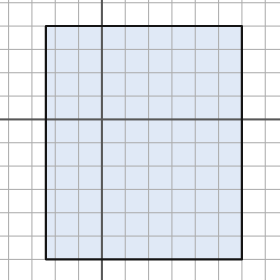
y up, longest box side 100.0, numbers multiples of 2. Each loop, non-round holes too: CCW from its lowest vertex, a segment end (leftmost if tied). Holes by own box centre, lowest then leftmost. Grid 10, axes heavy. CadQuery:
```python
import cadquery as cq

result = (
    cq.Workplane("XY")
    .moveTo(-24.0, -60.0)
    .lineTo(60.0, -60.0)
    .lineTo(60.0, 40.0)
    .lineTo(-24.0, 40.0)
    .close()
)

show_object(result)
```